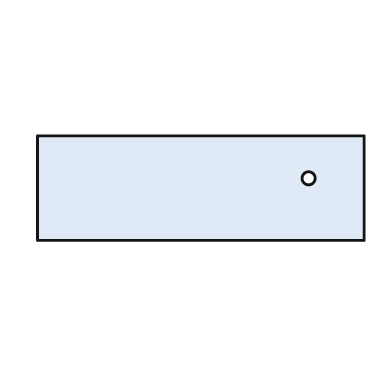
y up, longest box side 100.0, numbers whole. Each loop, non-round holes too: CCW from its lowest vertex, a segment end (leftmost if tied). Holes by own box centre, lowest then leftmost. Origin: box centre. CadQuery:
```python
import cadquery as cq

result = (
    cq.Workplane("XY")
    .moveTo(-50.0, -16.0)
    .lineTo(50.0, -16.0)
    .lineTo(50.0, 16.0)
    .lineTo(-50.0, 16.0)
    .close()
    .moveTo(33.0, 3.0)
    .circle(2.0)
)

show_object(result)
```